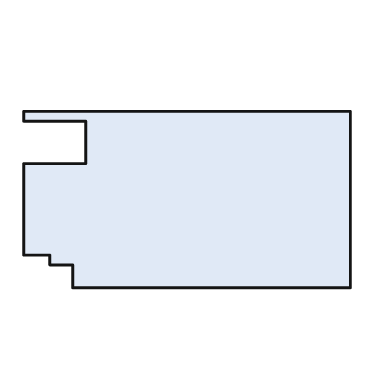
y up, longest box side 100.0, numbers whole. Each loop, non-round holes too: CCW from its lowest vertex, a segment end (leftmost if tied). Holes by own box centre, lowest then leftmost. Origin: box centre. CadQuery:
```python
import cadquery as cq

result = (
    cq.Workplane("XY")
    .moveTo(-35.0, -27.0)
    .lineTo(50.0, -27.0)
    .lineTo(50.0, 27.0)
    .lineTo(-50.0, 27.0)
    .lineTo(-50.0, 24.0)
    .lineTo(-31.0, 24.0)
    .lineTo(-31.0, 11.0)
    .lineTo(-50.0, 11.0)
    .lineTo(-50.0, -17.0)
    .lineTo(-42.0, -17.0)
    .lineTo(-42.0, -20.0)
    .lineTo(-35.0, -20.0)
    .close()
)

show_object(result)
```